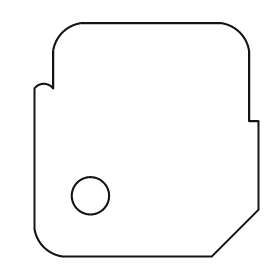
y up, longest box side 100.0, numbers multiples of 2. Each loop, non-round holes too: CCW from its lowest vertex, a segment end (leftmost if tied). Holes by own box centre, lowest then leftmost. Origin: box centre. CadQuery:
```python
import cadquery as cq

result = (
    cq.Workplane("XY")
    .moveTo(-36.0, -50.0)
    .lineTo(28.0, -50.0)
    .lineTo(48.0, -30.0)
    .lineTo(48.0, 8.0)
    .lineTo(44.0, 8.0)
    .lineTo(44.0, 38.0)
    .threePointArc((40.0, 46.0), (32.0, 50.0))
    .lineTo(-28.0, 50.0)
    .threePointArc((-36.0, 46.0), (-40.0, 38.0))
    .lineTo(-40.0, 22.0)
    .threePointArc((-44.0, 24.0), (-48.0, 22.0))
    .lineTo(-48.0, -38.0)
    .threePointArc((-44.0, -46.0), (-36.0, -50.0))
    .close()
    .moveTo(-24.0, -24.0)
    .circle(8.0)
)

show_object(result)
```